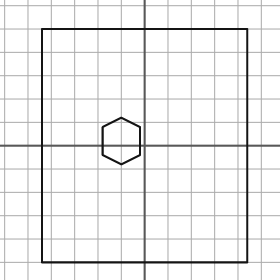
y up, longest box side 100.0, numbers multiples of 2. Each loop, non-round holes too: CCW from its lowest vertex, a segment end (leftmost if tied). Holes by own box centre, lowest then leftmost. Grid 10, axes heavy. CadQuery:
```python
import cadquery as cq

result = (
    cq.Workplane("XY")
    .moveTo(-44.0, -50.0)
    .lineTo(44.0, -50.0)
    .lineTo(44.0, 50.0)
    .lineTo(-44.0, 50.0)
    .close()
    .moveTo(-10.0, -8.0)
    .lineTo(-2.0, -4.0)
    .lineTo(-2.0, 8.0)
    .lineTo(-10.0, 12.0)
    .lineTo(-18.0, 8.0)
    .lineTo(-18.0, -4.0)
    .close()
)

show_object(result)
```